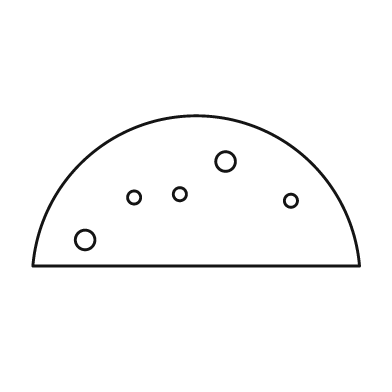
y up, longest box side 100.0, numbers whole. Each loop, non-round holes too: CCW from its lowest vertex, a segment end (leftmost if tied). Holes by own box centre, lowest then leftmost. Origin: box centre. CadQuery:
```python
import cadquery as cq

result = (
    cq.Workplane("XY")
    .moveTo(-50.0, -23.0)
    .lineTo(50.0, -23.0)
    .threePointArc((0.0, 23.0), (-50.0, -23.0))
    .close()
    .moveTo(-34.0, -15.0)
    .circle(3.0)
    .moveTo(29.0, -3.0)
    .circle(2.0)
    .moveTo(-19.0, -2.0)
    .circle(2.0)
    .moveTo(-5.0, -1.0)
    .circle(2.0)
    .moveTo(9.0, 9.0)
    .circle(3.0)
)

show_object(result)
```